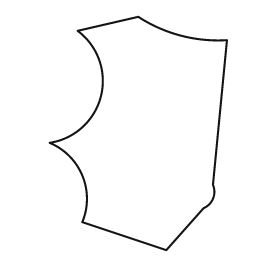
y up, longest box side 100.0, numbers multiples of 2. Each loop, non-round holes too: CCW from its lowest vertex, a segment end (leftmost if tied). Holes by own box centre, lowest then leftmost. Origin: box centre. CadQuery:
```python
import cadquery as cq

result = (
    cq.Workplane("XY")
    .moveTo(12.0, -50.0)
    .lineTo(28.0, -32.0)
    .threePointArc((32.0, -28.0), (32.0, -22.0))
    .lineTo(38.0, 40.0)
    .threePointArc((18.0, 42.0), (0.0, 50.0))
    .lineTo(-26.0, 44.0)
    .threePointArc((-16.0, 16.0), (-38.0, -4.0))
    .threePointArc((-24.0, -18.0), (-24.0, -38.0))
    .close()
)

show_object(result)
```